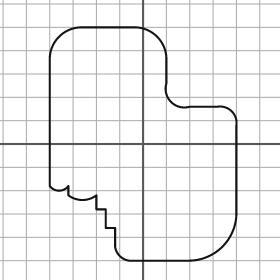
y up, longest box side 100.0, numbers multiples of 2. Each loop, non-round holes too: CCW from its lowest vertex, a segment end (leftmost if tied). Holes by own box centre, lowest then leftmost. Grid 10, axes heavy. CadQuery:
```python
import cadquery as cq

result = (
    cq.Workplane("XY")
    .moveTo(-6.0, -50.0)
    .lineTo(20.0, -50.0)
    .threePointArc((34.0, -44.0), (40.0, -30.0))
    .lineTo(40.0, 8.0)
    .threePointArc((38.0, 14.0), (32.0, 16.0))
    .lineTo(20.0, 16.0)
    .threePointArc((12.0, 18.0), (10.0, 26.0))
    .lineTo(10.0, 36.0)
    .threePointArc((6.0, 46.0), (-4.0, 50.0))
    .lineTo(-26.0, 50.0)
    .threePointArc((-36.0, 46.0), (-40.0, 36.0))
    .lineTo(-40.0, -18.0)
    .threePointArc((-36.0, -20.0), (-32.0, -18.0))
    .lineTo(-32.0, -22.0)
    .threePointArc((-26.0, -24.0), (-20.0, -22.0))
    .lineTo(-20.0, -28.0)
    .lineTo(-16.0, -28.0)
    .lineTo(-16.0, -36.0)
    .lineTo(-12.0, -36.0)
    .lineTo(-12.0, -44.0)
    .threePointArc((-10.0, -48.0), (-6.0, -50.0))
    .close()
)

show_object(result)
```